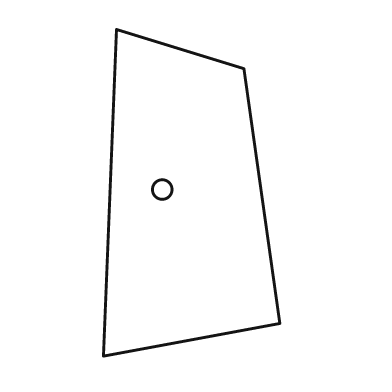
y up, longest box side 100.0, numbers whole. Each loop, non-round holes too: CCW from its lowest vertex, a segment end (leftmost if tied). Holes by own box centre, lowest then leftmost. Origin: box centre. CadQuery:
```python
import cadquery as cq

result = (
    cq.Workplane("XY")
    .moveTo(-27.0, -50.0)
    .lineTo(27.0, -40.0)
    .lineTo(16.0, 38.0)
    .lineTo(-23.0, 50.0)
    .close()
    .moveTo(-9.0, 1.0)
    .circle(3.0)
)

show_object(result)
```